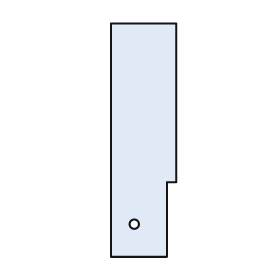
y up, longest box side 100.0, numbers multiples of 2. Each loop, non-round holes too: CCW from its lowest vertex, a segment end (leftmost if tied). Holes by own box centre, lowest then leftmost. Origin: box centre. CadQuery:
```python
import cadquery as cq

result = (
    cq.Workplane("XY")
    .moveTo(-14.0, -50.0)
    .lineTo(10.0, -50.0)
    .lineTo(10.0, -18.0)
    .lineTo(14.0, -18.0)
    .lineTo(14.0, 50.0)
    .lineTo(-14.0, 50.0)
    .close()
    .moveTo(-4.0, -36.0)
    .circle(2.0)
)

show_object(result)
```